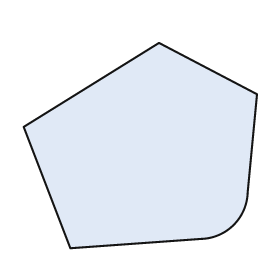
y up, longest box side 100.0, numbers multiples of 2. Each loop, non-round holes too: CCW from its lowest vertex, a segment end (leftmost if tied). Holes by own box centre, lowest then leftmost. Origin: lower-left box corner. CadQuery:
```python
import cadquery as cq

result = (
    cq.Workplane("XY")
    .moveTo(20.0, 0.0)
    .lineTo(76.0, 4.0)
    .threePointArc((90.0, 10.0), (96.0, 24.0))
    .lineTo(100.0, 66.0)
    .lineTo(58.0, 88.0)
    .lineTo(0.0, 52.0)
    .close()
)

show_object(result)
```